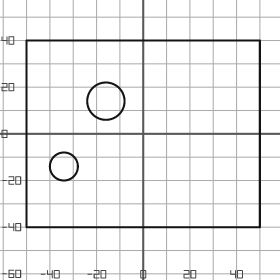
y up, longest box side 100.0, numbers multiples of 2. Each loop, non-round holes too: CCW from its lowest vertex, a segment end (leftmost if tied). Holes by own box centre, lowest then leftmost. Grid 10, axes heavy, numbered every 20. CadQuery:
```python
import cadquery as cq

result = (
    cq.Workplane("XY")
    .moveTo(-50.0, -40.0)
    .lineTo(50.0, -40.0)
    .lineTo(50.0, 40.0)
    .lineTo(-50.0, 40.0)
    .close()
    .moveTo(-34.0, -14.0)
    .circle(6.0)
    .moveTo(-16.0, 14.0)
    .circle(8.0)
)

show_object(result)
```